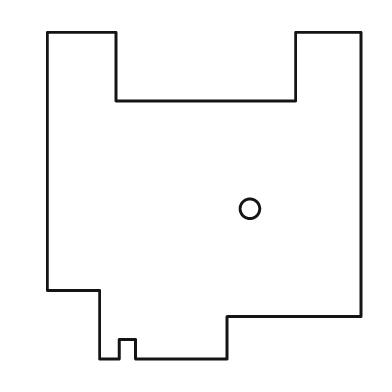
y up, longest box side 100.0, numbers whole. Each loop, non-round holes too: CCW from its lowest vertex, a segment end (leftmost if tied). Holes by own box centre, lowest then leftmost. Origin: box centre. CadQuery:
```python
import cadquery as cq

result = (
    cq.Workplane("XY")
    .moveTo(-32.0, -50.0)
    .lineTo(-26.0, -50.0)
    .lineTo(-26.0, -44.0)
    .lineTo(-21.0, -44.0)
    .lineTo(-21.0, -50.0)
    .lineTo(7.0, -50.0)
    .lineTo(7.0, -37.0)
    .lineTo(48.0, -37.0)
    .lineTo(48.0, 50.0)
    .lineTo(28.0, 50.0)
    .lineTo(28.0, 29.0)
    .lineTo(-27.0, 29.0)
    .lineTo(-27.0, 50.0)
    .lineTo(-48.0, 50.0)
    .lineTo(-48.0, -29.0)
    .lineTo(-32.0, -29.0)
    .close()
    .moveTo(14.0, -4.0)
    .circle(3.0)
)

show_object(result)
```